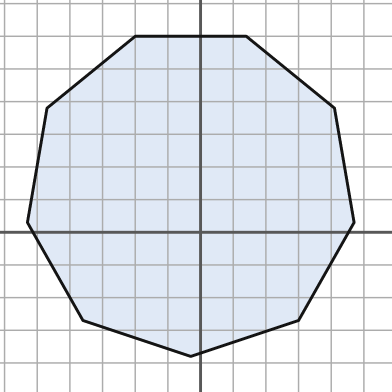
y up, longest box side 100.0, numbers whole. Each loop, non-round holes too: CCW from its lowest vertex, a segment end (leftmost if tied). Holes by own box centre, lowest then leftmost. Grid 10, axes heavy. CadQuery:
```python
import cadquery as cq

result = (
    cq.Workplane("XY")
    .moveTo(-3.0, -38.0)
    .lineTo(30.0, -27.0)
    .lineTo(47.0, 3.0)
    .lineTo(41.0, 38.0)
    .lineTo(14.0, 60.0)
    .lineTo(-20.0, 60.0)
    .lineTo(-47.0, 38.0)
    .lineTo(-53.0, 3.0)
    .lineTo(-36.0, -27.0)
    .close()
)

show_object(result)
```